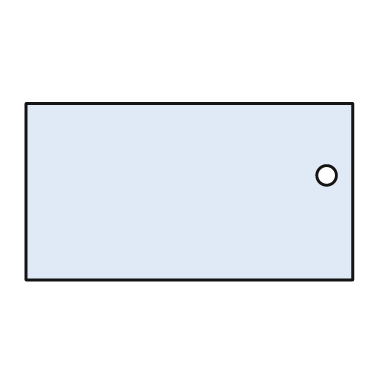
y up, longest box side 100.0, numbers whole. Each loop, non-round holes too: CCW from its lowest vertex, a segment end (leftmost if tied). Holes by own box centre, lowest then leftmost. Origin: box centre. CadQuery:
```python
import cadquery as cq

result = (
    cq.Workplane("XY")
    .moveTo(-50.0, -27.0)
    .lineTo(50.0, -27.0)
    .lineTo(50.0, 27.0)
    .lineTo(-50.0, 27.0)
    .close()
    .moveTo(42.0, 5.0)
    .circle(3.0)
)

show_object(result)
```